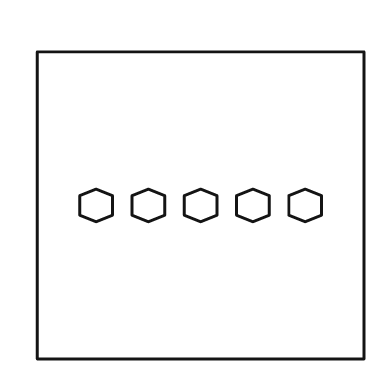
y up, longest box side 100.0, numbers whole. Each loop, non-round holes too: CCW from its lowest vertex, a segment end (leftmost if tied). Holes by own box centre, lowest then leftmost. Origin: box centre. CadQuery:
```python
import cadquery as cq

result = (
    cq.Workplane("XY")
    .moveTo(-50.0, -47.0)
    .lineTo(50.0, -47.0)
    .lineTo(50.0, 47.0)
    .lineTo(-50.0, 47.0)
    .close()
    .moveTo(-32.0, -5.0)
    .lineTo(-27.0, -3.0)
    .lineTo(-27.0, 3.0)
    .lineTo(-32.0, 5.0)
    .lineTo(-37.0, 3.0)
    .lineTo(-37.0, -3.0)
    .close()
    .moveTo(-16.0, -5.0)
    .lineTo(-11.0, -3.0)
    .lineTo(-11.0, 3.0)
    .lineTo(-16.0, 5.0)
    .lineTo(-21.0, 3.0)
    .lineTo(-21.0, -3.0)
    .close()
    .moveTo(0.0, -5.0)
    .lineTo(5.0, -3.0)
    .lineTo(5.0, 3.0)
    .lineTo(0.0, 5.0)
    .lineTo(-5.0, 3.0)
    .lineTo(-5.0, -3.0)
    .close()
    .moveTo(16.0, -5.0)
    .lineTo(21.0, -3.0)
    .lineTo(21.0, 3.0)
    .lineTo(16.0, 5.0)
    .lineTo(11.0, 3.0)
    .lineTo(11.0, -3.0)
    .close()
    .moveTo(32.0, -5.0)
    .lineTo(37.0, -3.0)
    .lineTo(37.0, 3.0)
    .lineTo(32.0, 5.0)
    .lineTo(27.0, 3.0)
    .lineTo(27.0, -3.0)
    .close()
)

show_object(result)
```